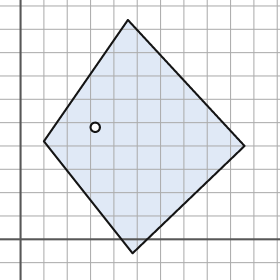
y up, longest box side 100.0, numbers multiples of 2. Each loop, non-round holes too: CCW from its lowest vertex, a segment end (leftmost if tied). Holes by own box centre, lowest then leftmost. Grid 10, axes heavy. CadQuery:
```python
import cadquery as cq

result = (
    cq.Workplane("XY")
    .moveTo(48.0, -6.0)
    .lineTo(96.0, 40.0)
    .lineTo(46.0, 94.0)
    .lineTo(10.0, 42.0)
    .close()
    .moveTo(32.0, 48.0)
    .circle(2.0)
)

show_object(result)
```